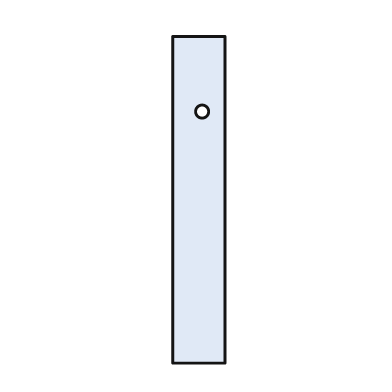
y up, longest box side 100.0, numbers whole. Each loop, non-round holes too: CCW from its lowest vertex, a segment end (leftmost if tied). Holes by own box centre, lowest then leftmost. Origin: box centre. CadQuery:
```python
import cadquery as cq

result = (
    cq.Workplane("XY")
    .moveTo(-8.0, -50.0)
    .lineTo(8.0, -50.0)
    .lineTo(8.0, 50.0)
    .lineTo(-8.0, 50.0)
    .close()
    .moveTo(1.0, 27.0)
    .circle(2.0)
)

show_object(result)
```